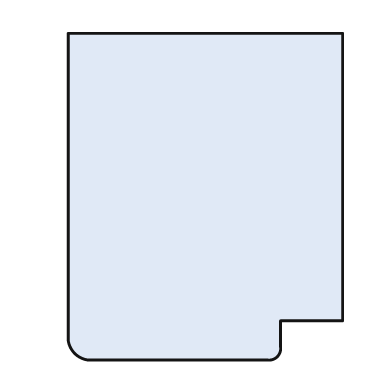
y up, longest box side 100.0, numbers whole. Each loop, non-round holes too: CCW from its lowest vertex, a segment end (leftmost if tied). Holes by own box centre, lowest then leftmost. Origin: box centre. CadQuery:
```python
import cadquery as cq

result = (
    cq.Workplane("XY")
    .moveTo(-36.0, -50.0)
    .lineTo(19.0, -50.0)
    .threePointArc((22.0, -49.0), (23.0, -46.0))
    .lineTo(23.0, -38.0)
    .lineTo(42.0, -38.0)
    .lineTo(42.0, 50.0)
    .lineTo(-42.0, 50.0)
    .lineTo(-42.0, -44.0)
    .threePointArc((-40.0, -48.0), (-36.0, -50.0))
    .close()
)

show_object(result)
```